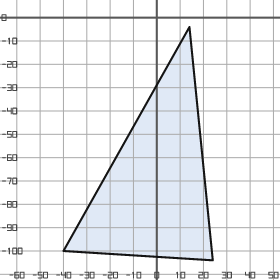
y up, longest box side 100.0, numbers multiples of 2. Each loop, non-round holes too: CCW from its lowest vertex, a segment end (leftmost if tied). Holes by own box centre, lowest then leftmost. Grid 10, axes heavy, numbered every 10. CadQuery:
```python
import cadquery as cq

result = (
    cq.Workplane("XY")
    .moveTo(24.0, -104.0)
    .lineTo(14.0, -4.0)
    .lineTo(-40.0, -100.0)
    .close()
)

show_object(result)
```